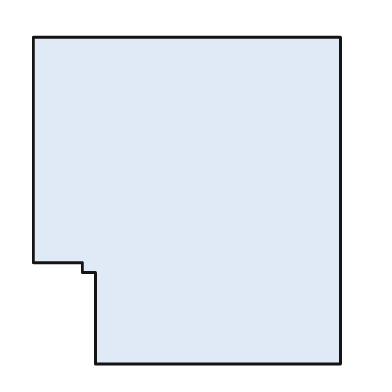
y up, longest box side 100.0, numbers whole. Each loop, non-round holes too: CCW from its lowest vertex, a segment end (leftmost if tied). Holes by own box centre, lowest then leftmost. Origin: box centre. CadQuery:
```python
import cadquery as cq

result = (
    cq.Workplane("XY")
    .moveTo(-28.0, -50.0)
    .lineTo(47.0, -50.0)
    .lineTo(47.0, 50.0)
    .lineTo(-47.0, 50.0)
    .lineTo(-47.0, -19.0)
    .lineTo(-32.0, -19.0)
    .lineTo(-32.0, -22.0)
    .lineTo(-28.0, -22.0)
    .close()
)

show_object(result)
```